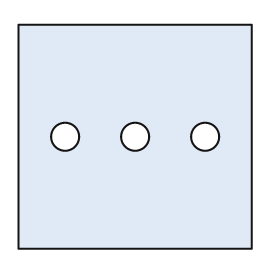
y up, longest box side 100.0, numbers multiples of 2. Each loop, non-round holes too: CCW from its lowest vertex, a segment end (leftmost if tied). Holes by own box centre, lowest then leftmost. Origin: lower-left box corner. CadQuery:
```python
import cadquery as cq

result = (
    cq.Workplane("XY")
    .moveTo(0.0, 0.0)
    .lineTo(100.0, 0.0)
    .lineTo(100.0, 96.0)
    .lineTo(0.0, 96.0)
    .close()
    .moveTo(20.0, 48.0)
    .circle(6.0)
    .moveTo(50.0, 48.0)
    .circle(6.0)
    .moveTo(80.0, 48.0)
    .circle(6.0)
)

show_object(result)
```